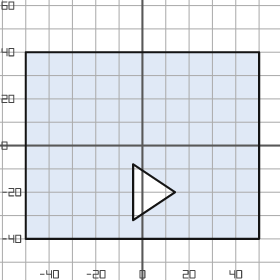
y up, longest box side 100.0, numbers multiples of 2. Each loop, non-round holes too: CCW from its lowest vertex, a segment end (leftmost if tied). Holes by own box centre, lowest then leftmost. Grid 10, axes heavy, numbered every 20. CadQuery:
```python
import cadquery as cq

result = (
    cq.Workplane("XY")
    .moveTo(-50.0, -40.0)
    .lineTo(50.0, -40.0)
    .lineTo(50.0, 40.0)
    .lineTo(-50.0, 40.0)
    .close()
    .moveTo(-4.0, -32.0)
    .lineTo(14.0, -20.0)
    .lineTo(-4.0, -8.0)
    .close()
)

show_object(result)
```